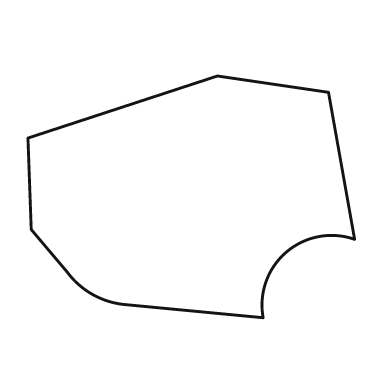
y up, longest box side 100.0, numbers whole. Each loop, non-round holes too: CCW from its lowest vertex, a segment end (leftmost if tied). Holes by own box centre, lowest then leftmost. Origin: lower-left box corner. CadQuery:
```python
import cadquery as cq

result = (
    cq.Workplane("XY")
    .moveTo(72.0, 0.0)
    .threePointArc((79.0, 20.0), (100.0, 24.0))
    .lineTo(92.0, 69.0)
    .lineTo(58.0, 74.0)
    .lineTo(0.0, 55.0)
    .lineTo(1.0, 27.0)
    .lineTo(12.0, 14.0)
    .threePointArc((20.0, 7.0), (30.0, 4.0))
    .close()
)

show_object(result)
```